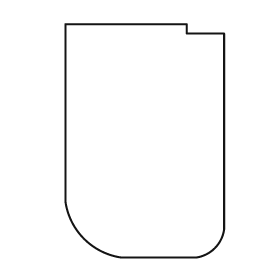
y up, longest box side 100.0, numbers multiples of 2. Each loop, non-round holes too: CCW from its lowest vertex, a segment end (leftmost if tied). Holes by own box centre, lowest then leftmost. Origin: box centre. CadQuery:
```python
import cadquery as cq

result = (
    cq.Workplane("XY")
    .moveTo(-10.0, -50.0)
    .lineTo(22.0, -50.0)
    .threePointArc((30.0, -46.0), (34.0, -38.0))
    .lineTo(34.0, 46.0)
    .lineTo(18.0, 46.0)
    .lineTo(18.0, 50.0)
    .lineTo(-34.0, 50.0)
    .lineTo(-34.0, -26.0)
    .threePointArc((-26.0, -42.0), (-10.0, -50.0))
    .close()
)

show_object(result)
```